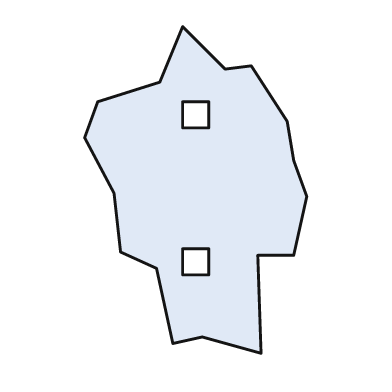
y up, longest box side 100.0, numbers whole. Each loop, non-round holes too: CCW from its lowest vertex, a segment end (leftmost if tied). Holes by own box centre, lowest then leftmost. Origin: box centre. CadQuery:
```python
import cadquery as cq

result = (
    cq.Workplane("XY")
    .moveTo(20.0, -50.0)
    .lineTo(19.0, -20.0)
    .lineTo(30.0, -20.0)
    .lineTo(34.0, -2.0)
    .lineTo(30.0, 9.0)
    .lineTo(28.0, 21.0)
    .lineTo(17.0, 38.0)
    .lineTo(9.0, 37.0)
    .lineTo(-4.0, 50.0)
    .lineTo(-11.0, 33.0)
    .lineTo(-30.0, 27.0)
    .lineTo(-34.0, 16.0)
    .lineTo(-25.0, -1.0)
    .lineTo(-23.0, -19.0)
    .lineTo(-12.0, -24.0)
    .lineTo(-7.0, -47.0)
    .lineTo(2.0, -45.0)
    .close()
    .moveTo(-4.0, -26.0)
    .lineTo(4.0, -26.0)
    .lineTo(4.0, -18.0)
    .lineTo(-4.0, -18.0)
    .close()
    .moveTo(-4.0, 19.0)
    .lineTo(4.0, 19.0)
    .lineTo(4.0, 27.0)
    .lineTo(-4.0, 27.0)
    .close()
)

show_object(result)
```